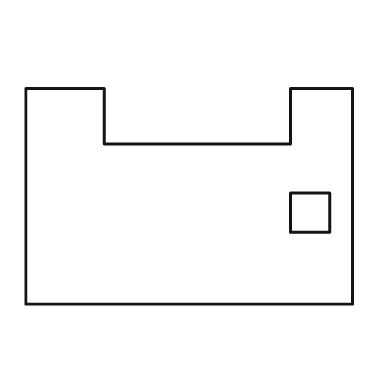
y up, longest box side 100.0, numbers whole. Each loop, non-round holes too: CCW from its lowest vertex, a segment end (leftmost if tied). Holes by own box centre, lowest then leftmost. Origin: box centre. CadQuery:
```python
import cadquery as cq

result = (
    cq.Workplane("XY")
    .moveTo(-50.0, -33.0)
    .lineTo(50.0, -33.0)
    .lineTo(50.0, 33.0)
    .lineTo(31.0, 33.0)
    .lineTo(31.0, 16.0)
    .lineTo(-26.0, 16.0)
    .lineTo(-26.0, 33.0)
    .lineTo(-50.0, 33.0)
    .close()
    .moveTo(31.0, -11.0)
    .lineTo(43.0, -11.0)
    .lineTo(43.0, 1.0)
    .lineTo(31.0, 1.0)
    .close()
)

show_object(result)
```